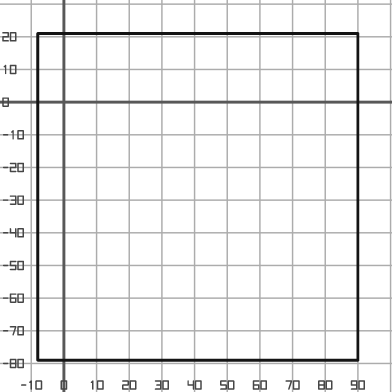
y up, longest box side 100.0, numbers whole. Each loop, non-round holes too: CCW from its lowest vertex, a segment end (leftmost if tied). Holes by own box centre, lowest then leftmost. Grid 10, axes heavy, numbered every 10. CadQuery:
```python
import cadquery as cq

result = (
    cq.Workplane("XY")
    .moveTo(-8.0, -79.0)
    .lineTo(90.0, -79.0)
    .lineTo(90.0, 21.0)
    .lineTo(-8.0, 21.0)
    .close()
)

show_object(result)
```